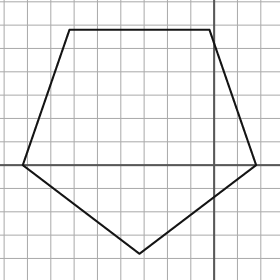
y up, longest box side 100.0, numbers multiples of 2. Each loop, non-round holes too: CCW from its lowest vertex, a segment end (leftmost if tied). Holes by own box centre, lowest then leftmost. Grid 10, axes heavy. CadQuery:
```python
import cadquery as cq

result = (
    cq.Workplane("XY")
    .moveTo(-32.0, -38.0)
    .lineTo(18.0, 0.0)
    .lineTo(-2.0, 58.0)
    .lineTo(-62.0, 58.0)
    .lineTo(-82.0, 0.0)
    .close()
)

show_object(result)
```